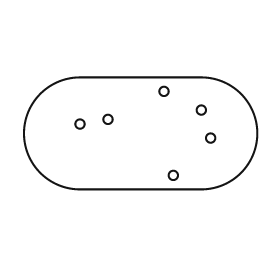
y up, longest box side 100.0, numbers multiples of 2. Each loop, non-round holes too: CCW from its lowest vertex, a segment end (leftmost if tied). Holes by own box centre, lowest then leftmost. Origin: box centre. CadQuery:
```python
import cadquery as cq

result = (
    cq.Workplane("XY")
    .moveTo(-26.0, -24.0)
    .lineTo(26.0, -24.0)
    .threePointArc((50.0, 0.0), (26.0, 24.0))
    .lineTo(-26.0, 24.0)
    .threePointArc((-50.0, 0.0), (-26.0, -24.0))
    .close()
    .moveTo(14.0, -18.0)
    .circle(2.0)
    .moveTo(30.0, -2.0)
    .circle(2.0)
    .moveTo(-26.0, 4.0)
    .circle(2.0)
    .moveTo(-14.0, 6.0)
    .circle(2.0)
    .moveTo(26.0, 10.0)
    .circle(2.0)
    .moveTo(10.0, 18.0)
    .circle(2.0)
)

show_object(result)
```